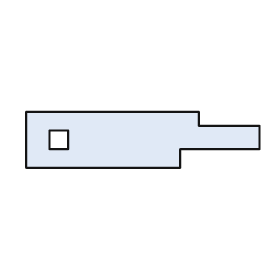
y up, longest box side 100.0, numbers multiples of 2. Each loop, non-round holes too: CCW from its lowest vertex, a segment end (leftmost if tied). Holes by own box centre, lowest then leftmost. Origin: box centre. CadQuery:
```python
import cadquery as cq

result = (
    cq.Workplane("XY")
    .moveTo(-50.0, -12.0)
    .lineTo(16.0, -12.0)
    .lineTo(16.0, -4.0)
    .lineTo(50.0, -4.0)
    .lineTo(50.0, 6.0)
    .lineTo(24.0, 6.0)
    .lineTo(24.0, 12.0)
    .lineTo(-50.0, 12.0)
    .close()
    .moveTo(-40.0, -4.0)
    .lineTo(-32.0, -4.0)
    .lineTo(-32.0, 4.0)
    .lineTo(-40.0, 4.0)
    .close()
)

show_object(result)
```